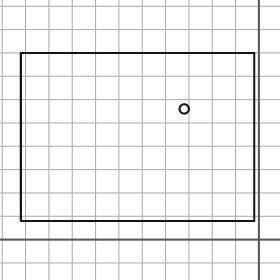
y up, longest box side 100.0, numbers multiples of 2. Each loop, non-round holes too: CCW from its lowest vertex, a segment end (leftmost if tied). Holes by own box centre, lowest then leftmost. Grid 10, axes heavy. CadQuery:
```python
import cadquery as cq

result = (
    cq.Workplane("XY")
    .moveTo(-102.0, 8.0)
    .lineTo(-2.0, 8.0)
    .lineTo(-2.0, 80.0)
    .lineTo(-102.0, 80.0)
    .close()
    .moveTo(-32.0, 56.0)
    .circle(2.0)
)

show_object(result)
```